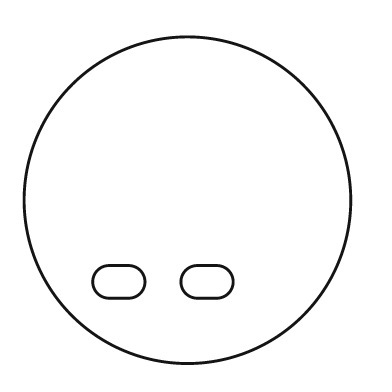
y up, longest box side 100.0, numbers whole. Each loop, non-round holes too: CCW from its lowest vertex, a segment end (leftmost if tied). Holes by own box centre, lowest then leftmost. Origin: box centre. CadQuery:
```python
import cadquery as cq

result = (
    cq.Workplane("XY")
    .moveTo(0.0, 0.0)
    .circle(50.0)
    .moveTo(-24.0, -30.0)
    .lineTo(-18.0, -30.0)
    .threePointArc((-13.0, -25.0), (-18.0, -20.0))
    .lineTo(-24.0, -20.0)
    .threePointArc((-29.0, -25.0), (-24.0, -30.0))
    .close()
    .moveTo(3.0, -30.0)
    .lineTo(9.0, -30.0)
    .threePointArc((14.0, -25.0), (9.0, -20.0))
    .lineTo(3.0, -20.0)
    .threePointArc((-2.0, -25.0), (3.0, -30.0))
    .close()
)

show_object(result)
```